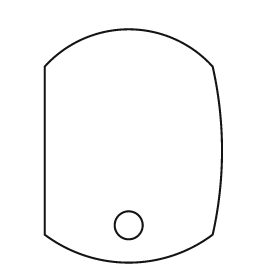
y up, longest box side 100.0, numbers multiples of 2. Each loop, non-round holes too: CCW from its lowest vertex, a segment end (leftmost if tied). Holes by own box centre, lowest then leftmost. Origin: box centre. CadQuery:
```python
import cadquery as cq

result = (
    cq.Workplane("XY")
    .moveTo(-38.0, -38.0)
    .threePointArc((-2.0, -50.0), (34.0, -38.0))
    .threePointArc((38.0, -2.0), (34.0, 34.0))
    .threePointArc((-2.0, 50.0), (-38.0, 34.0))
    .close()
    .moveTo(-2.0, -34.0)
    .circle(6.0)
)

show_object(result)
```